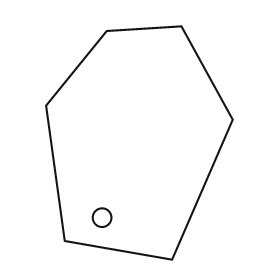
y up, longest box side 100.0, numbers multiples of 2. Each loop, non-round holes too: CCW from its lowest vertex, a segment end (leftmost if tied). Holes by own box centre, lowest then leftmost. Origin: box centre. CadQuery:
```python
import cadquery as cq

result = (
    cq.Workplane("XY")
    .moveTo(14.0, -50.0)
    .lineTo(40.0, 10.0)
    .lineTo(18.0, 50.0)
    .lineTo(-14.0, 48.0)
    .lineTo(-40.0, 16.0)
    .lineTo(-32.0, -42.0)
    .close()
    .moveTo(-16.0, -32.0)
    .circle(4.0)
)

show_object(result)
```